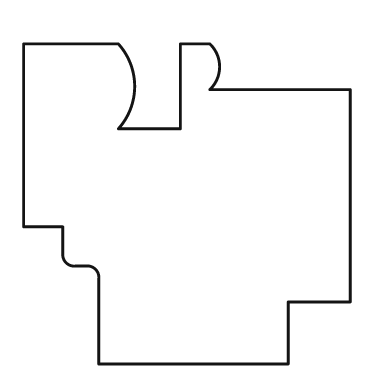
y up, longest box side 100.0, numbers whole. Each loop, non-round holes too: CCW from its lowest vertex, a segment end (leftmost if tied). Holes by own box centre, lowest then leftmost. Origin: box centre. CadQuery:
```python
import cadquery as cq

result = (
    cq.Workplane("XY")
    .moveTo(-27.0, -49.0)
    .lineTo(31.0, -49.0)
    .lineTo(31.0, -30.0)
    .lineTo(50.0, -30.0)
    .lineTo(50.0, 35.0)
    .lineTo(7.0, 35.0)
    .threePointArc((10.0, 42.0), (7.0, 49.0))
    .lineTo(-2.0, 49.0)
    .lineTo(-2.0, 23.0)
    .lineTo(-21.0, 23.0)
    .threePointArc((-16.0, 36.0), (-21.0, 49.0))
    .lineTo(-50.0, 49.0)
    .lineTo(-50.0, -7.0)
    .lineTo(-38.0, -7.0)
    .lineTo(-38.0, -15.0)
    .threePointArc((-37.0, -18.0), (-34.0, -19.0))
    .lineTo(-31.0, -19.0)
    .threePointArc((-28.0, -20.0), (-27.0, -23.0))
    .close()
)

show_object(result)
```